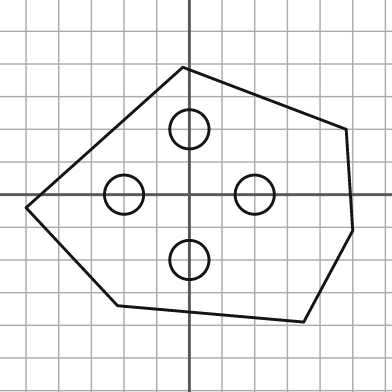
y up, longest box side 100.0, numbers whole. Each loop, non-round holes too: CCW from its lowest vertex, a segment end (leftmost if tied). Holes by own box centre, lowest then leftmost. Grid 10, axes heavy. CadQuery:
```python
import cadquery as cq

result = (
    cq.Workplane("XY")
    .moveTo(35.0, -39.0)
    .lineTo(50.0, -11.0)
    .lineTo(48.0, 20.0)
    .lineTo(-2.0, 39.0)
    .lineTo(-50.0, -4.0)
    .lineTo(-22.0, -34.0)
    .close()
    .moveTo(0.0, -20.0)
    .circle(6.0)
    .moveTo(-20.0, 0.0)
    .circle(6.0)
    .moveTo(20.0, 0.0)
    .circle(6.0)
    .moveTo(0.0, 20.0)
    .circle(6.0)
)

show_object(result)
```